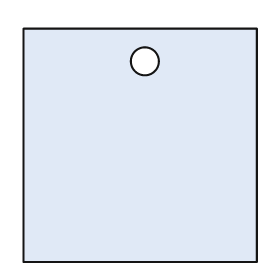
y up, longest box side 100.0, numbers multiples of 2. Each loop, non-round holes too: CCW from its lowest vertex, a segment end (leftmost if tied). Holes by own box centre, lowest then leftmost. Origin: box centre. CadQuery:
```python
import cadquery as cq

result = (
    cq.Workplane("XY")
    .moveTo(-50.0, -50.0)
    .lineTo(50.0, -50.0)
    .lineTo(50.0, 50.0)
    .lineTo(-50.0, 50.0)
    .close()
    .moveTo(2.0, 36.0)
    .circle(6.0)
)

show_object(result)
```